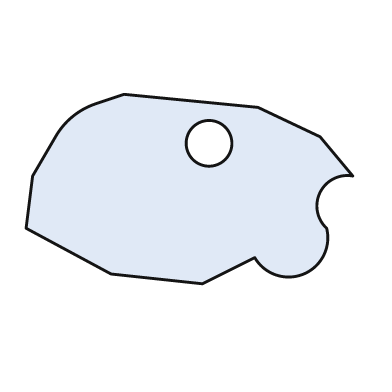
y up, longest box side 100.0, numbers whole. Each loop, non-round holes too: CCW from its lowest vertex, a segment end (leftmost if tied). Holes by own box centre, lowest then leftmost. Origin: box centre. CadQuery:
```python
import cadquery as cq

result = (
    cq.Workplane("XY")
    .moveTo(4.0, -29.0)
    .lineTo(20.0, -21.0)
    .threePointArc((35.0, -26.0), (42.0, -12.0))
    .threePointArc((40.0, -1.0), (50.0, 4.0))
    .lineTo(40.0, 16.0)
    .lineTo(21.0, 25.0)
    .lineTo(-20.0, 29.0)
    .lineTo(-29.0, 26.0)
    .threePointArc((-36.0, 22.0), (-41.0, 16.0))
    .lineTo(-48.0, 4.0)
    .lineTo(-50.0, -12.0)
    .lineTo(-24.0, -26.0)
    .close()
    .moveTo(6.0, 14.0)
    .circle(7.0)
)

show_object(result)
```